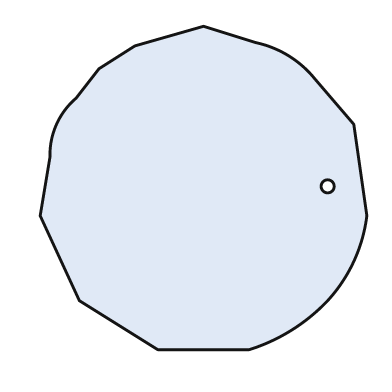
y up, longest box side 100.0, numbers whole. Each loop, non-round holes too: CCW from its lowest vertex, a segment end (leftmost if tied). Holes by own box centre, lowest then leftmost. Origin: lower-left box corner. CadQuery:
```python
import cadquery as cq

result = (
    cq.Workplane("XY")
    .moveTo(36.0, 0.0)
    .lineTo(64.0, 0.0)
    .threePointArc((77.0, 6.0), (88.0, 15.0))
    .threePointArc((96.0, 27.0), (100.0, 41.0))
    .lineTo(96.0, 69.0)
    .lineTo(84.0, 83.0)
    .threePointArc((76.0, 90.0), (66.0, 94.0))
    .lineTo(50.0, 99.0)
    .lineTo(29.0, 93.0)
    .lineTo(18.0, 86.0)
    .lineTo(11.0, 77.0)
    .threePointArc((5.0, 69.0), (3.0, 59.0))
    .lineTo(0.0, 41.0)
    .lineTo(12.0, 15.0)
    .close()
    .moveTo(88.0, 50.0)
    .circle(2.0)
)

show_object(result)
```